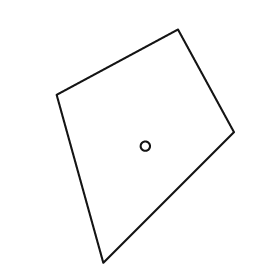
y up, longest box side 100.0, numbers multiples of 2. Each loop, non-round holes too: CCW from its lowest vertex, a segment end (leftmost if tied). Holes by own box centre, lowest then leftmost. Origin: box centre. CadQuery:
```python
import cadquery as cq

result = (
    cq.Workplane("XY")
    .moveTo(-18.0, -50.0)
    .lineTo(38.0, 6.0)
    .lineTo(14.0, 50.0)
    .lineTo(-38.0, 22.0)
    .close()
    .moveTo(0.0, 0.0)
    .circle(2.0)
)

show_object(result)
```